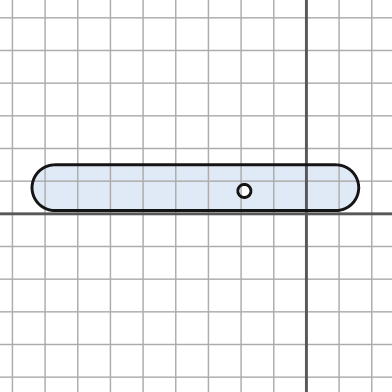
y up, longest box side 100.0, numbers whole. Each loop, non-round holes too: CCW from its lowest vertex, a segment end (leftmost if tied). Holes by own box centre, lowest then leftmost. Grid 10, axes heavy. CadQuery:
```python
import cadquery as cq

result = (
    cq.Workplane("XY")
    .moveTo(-77.0, 1.0)
    .lineTo(9.0, 1.0)
    .threePointArc((16.0, 8.0), (9.0, 15.0))
    .lineTo(-77.0, 15.0)
    .threePointArc((-84.0, 8.0), (-77.0, 1.0))
    .close()
    .moveTo(-19.0, 7.0)
    .circle(2.0)
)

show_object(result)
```